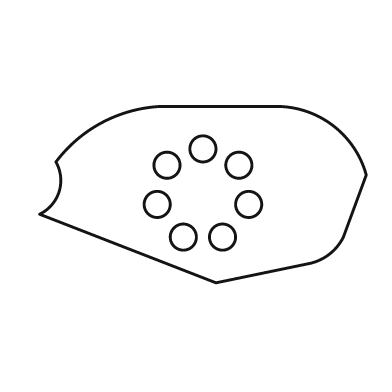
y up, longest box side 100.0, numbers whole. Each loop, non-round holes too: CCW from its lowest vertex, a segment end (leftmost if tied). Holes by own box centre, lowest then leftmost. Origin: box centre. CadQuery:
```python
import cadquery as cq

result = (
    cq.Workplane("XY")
    .moveTo(4.0, -27.0)
    .lineTo(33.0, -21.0)
    .threePointArc((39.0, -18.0), (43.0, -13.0))
    .lineTo(50.0, 6.0)
    .threePointArc((40.0, 21.0), (23.0, 27.0))
    .lineTo(-13.0, 27.0)
    .threePointArc((-31.0, 22.0), (-45.0, 10.0))
    .threePointArc((-44.0, 1.0), (-50.0, -6.0))
    .close()
    .moveTo(-6.0, -13.0)
    .circle(4.0)
    .moveTo(6.0, -13.0)
    .circle(4.0)
    .moveTo(-14.0, -3.0)
    .circle(4.0)
    .moveTo(14.0, -3.0)
    .circle(4.0)
    .moveTo(-11.0, 9.0)
    .circle(4.0)
    .moveTo(11.0, 9.0)
    .circle(4.0)
    .moveTo(0.0, 14.0)
    .circle(4.0)
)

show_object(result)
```